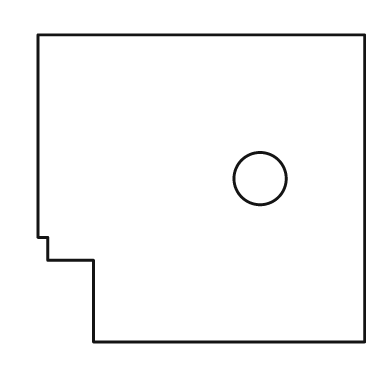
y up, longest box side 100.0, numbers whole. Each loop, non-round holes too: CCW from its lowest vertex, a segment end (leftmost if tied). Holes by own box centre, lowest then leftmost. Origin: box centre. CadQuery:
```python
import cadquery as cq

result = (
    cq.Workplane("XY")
    .moveTo(-33.0, -47.0)
    .lineTo(50.0, -47.0)
    .lineTo(50.0, 47.0)
    .lineTo(-50.0, 47.0)
    .lineTo(-50.0, -15.0)
    .lineTo(-47.0, -15.0)
    .lineTo(-47.0, -22.0)
    .lineTo(-33.0, -22.0)
    .close()
    .moveTo(18.0, 3.0)
    .circle(8.0)
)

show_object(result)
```